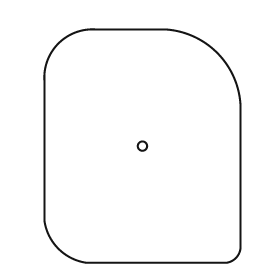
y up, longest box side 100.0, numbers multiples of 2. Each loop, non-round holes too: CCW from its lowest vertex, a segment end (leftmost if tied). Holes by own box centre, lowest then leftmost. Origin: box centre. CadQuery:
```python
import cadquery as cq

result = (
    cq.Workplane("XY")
    .moveTo(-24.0, -50.0)
    .lineTo(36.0, -50.0)
    .threePointArc((40.0, -48.0), (42.0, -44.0))
    .lineTo(42.0, 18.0)
    .threePointArc((32.0, 40.0), (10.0, 50.0))
    .lineTo(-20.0, 50.0)
    .threePointArc((-36.0, 44.0), (-42.0, 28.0))
    .lineTo(-42.0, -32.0)
    .threePointArc((-36.0, -44.0), (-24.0, -50.0))
    .close()
    .moveTo(0.0, 0.0)
    .circle(2.0)
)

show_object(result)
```